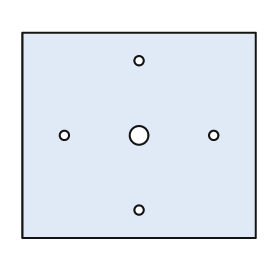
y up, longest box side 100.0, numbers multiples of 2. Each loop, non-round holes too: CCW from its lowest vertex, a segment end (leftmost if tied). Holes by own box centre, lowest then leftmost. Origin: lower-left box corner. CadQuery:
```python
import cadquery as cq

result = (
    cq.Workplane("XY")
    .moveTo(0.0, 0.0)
    .lineTo(100.0, 0.0)
    .lineTo(100.0, 88.0)
    .lineTo(0.0, 88.0)
    .close()
    .moveTo(50.0, 12.0)
    .circle(2.0)
    .moveTo(18.0, 44.0)
    .circle(2.0)
    .moveTo(50.0, 44.0)
    .circle(4.0)
    .moveTo(82.0, 44.0)
    .circle(2.0)
    .moveTo(50.0, 76.0)
    .circle(2.0)
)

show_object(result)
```